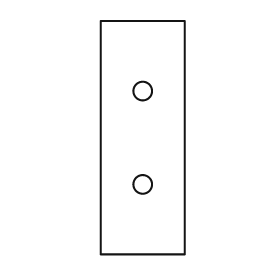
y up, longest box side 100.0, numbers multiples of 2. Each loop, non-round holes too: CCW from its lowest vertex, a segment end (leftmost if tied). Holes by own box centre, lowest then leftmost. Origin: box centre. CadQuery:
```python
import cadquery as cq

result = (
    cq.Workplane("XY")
    .moveTo(-18.0, -50.0)
    .lineTo(18.0, -50.0)
    .lineTo(18.0, 50.0)
    .lineTo(-18.0, 50.0)
    .close()
    .moveTo(0.0, -20.0)
    .circle(4.0)
    .moveTo(0.0, 20.0)
    .circle(4.0)
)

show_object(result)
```